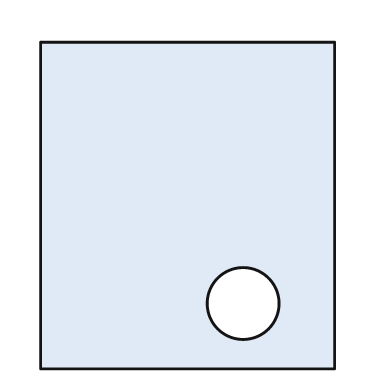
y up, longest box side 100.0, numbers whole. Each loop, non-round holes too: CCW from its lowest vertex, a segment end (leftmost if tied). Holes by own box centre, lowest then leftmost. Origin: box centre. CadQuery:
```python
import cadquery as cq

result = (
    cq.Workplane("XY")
    .moveTo(-45.0, -50.0)
    .lineTo(45.0, -50.0)
    .lineTo(45.0, 50.0)
    .lineTo(-45.0, 50.0)
    .close()
    .moveTo(17.0, -30.0)
    .circle(11.0)
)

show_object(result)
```